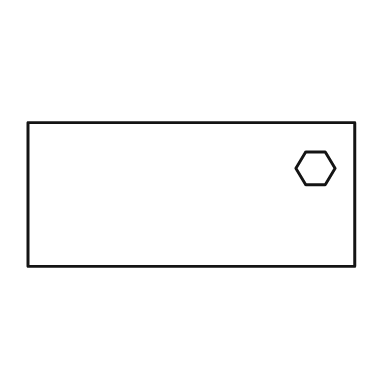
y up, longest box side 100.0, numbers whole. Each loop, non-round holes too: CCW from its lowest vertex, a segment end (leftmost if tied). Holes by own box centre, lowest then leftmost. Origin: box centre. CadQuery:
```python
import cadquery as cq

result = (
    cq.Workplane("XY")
    .moveTo(-50.0, -22.0)
    .lineTo(50.0, -22.0)
    .lineTo(50.0, 22.0)
    .lineTo(-50.0, 22.0)
    .close()
    .moveTo(35.0, 3.0)
    .lineTo(41.0, 3.0)
    .lineTo(44.0, 8.0)
    .lineTo(41.0, 13.0)
    .lineTo(35.0, 13.0)
    .lineTo(32.0, 8.0)
    .close()
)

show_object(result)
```